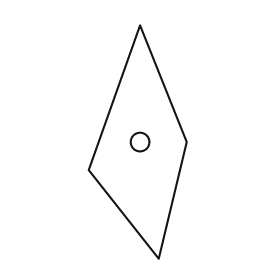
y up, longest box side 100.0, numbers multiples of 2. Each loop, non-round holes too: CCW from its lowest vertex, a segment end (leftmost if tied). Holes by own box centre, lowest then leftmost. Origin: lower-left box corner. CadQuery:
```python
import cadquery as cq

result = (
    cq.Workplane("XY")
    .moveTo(30.0, 0.0)
    .lineTo(42.0, 50.0)
    .lineTo(22.0, 100.0)
    .lineTo(0.0, 38.0)
    .close()
    .moveTo(22.0, 50.0)
    .circle(4.0)
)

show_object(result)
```